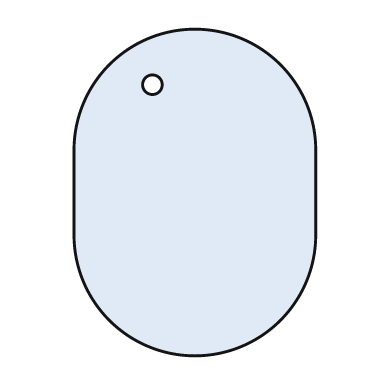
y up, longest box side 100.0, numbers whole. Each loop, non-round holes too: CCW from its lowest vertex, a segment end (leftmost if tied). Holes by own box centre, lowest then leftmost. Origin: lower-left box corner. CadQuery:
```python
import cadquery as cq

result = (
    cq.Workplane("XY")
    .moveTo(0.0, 37.0)
    .threePointArc((37.0, 0.0), (74.0, 37.0))
    .lineTo(74.0, 63.0)
    .threePointArc((37.0, 100.0), (0.0, 63.0))
    .close()
    .moveTo(24.0, 83.0)
    .circle(3.0)
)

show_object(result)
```